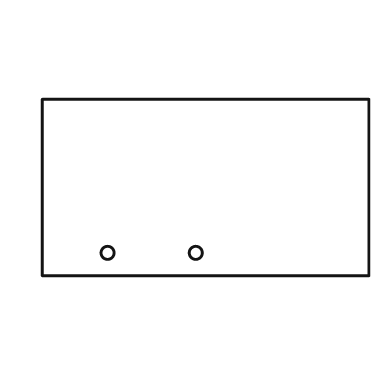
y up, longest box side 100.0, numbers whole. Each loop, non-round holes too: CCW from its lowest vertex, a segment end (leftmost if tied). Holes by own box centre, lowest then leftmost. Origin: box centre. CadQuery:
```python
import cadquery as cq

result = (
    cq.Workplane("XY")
    .moveTo(-50.0, -27.0)
    .lineTo(50.0, -27.0)
    .lineTo(50.0, 27.0)
    .lineTo(-50.0, 27.0)
    .close()
    .moveTo(-30.0, -20.0)
    .circle(2.0)
    .moveTo(-3.0, -20.0)
    .circle(2.0)
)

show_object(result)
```